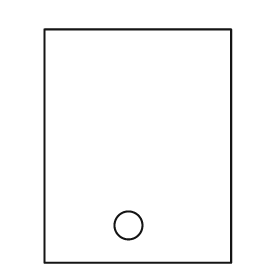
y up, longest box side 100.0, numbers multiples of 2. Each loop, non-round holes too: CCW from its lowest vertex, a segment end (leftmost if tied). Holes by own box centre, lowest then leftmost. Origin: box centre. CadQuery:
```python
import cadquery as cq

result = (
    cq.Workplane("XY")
    .moveTo(-40.0, -50.0)
    .lineTo(40.0, -50.0)
    .lineTo(40.0, 50.0)
    .lineTo(-40.0, 50.0)
    .close()
    .moveTo(-4.0, -34.0)
    .circle(6.0)
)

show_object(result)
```